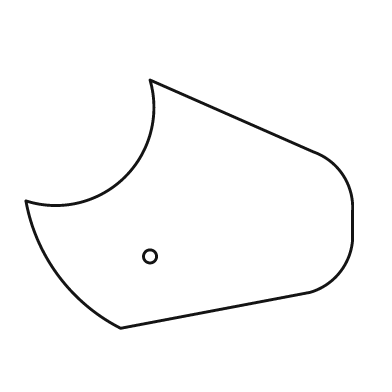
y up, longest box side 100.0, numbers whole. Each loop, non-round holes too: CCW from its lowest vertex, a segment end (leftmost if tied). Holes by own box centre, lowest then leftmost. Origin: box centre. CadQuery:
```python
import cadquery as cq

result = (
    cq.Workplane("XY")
    .moveTo(-21.0, -38.0)
    .lineTo(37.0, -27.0)
    .threePointArc((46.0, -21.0), (50.0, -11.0))
    .lineTo(50.0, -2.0)
    .threePointArc((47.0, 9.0), (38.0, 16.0))
    .lineTo(-12.0, 38.0)
    .threePointArc((-20.0, 8.0), (-50.0, 1.0))
    .threePointArc((-40.0, -22.0), (-21.0, -38.0))
    .close()
    .moveTo(-12.0, -16.0)
    .circle(2.0)
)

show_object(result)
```